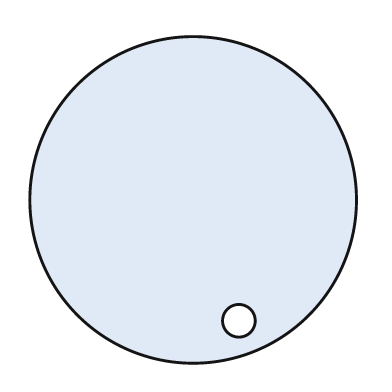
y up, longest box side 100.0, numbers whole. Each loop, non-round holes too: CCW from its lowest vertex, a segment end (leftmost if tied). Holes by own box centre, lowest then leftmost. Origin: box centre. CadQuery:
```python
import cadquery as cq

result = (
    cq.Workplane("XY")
    .moveTo(0.0, 0.0)
    .circle(50.0)
    .moveTo(14.0, -37.0)
    .circle(5.0)
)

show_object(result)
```